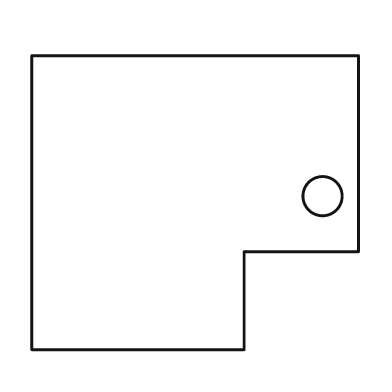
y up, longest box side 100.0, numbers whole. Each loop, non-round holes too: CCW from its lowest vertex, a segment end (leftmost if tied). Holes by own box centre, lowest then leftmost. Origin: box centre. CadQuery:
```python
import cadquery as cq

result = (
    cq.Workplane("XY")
    .moveTo(-50.0, -45.0)
    .lineTo(15.0, -45.0)
    .lineTo(15.0, -15.0)
    .lineTo(50.0, -15.0)
    .lineTo(50.0, 45.0)
    .lineTo(-50.0, 45.0)
    .close()
    .moveTo(39.0, 2.0)
    .circle(6.0)
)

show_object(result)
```